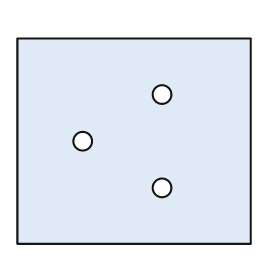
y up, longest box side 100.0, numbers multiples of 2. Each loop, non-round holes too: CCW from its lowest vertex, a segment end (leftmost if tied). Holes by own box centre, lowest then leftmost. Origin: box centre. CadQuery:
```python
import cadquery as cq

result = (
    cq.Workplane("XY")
    .moveTo(-50.0, -44.0)
    .lineTo(50.0, -44.0)
    .lineTo(50.0, 44.0)
    .lineTo(-50.0, 44.0)
    .close()
    .moveTo(12.0, -20.0)
    .circle(4.0)
    .moveTo(-22.0, 0.0)
    .circle(4.0)
    .moveTo(12.0, 20.0)
    .circle(4.0)
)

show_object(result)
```